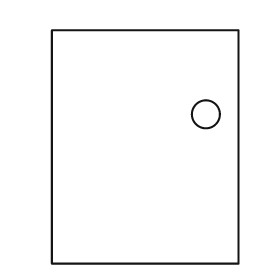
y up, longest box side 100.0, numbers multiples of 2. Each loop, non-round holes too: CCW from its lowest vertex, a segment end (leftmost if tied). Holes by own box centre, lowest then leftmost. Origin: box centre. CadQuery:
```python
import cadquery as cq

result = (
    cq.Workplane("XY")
    .moveTo(-40.0, -50.0)
    .lineTo(40.0, -50.0)
    .lineTo(40.0, 50.0)
    .lineTo(-40.0, 50.0)
    .close()
    .moveTo(26.0, 14.0)
    .circle(6.0)
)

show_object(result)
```